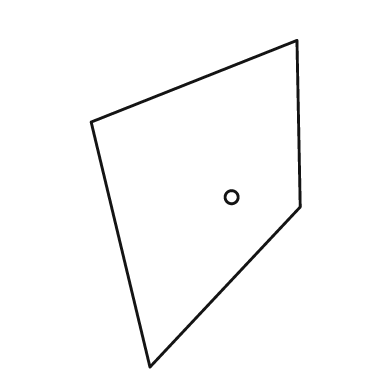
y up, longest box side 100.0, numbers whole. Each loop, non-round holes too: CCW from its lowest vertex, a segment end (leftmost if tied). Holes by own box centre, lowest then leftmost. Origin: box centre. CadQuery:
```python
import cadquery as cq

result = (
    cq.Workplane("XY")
    .moveTo(-14.0, -50.0)
    .lineTo(32.0, -1.0)
    .lineTo(31.0, 50.0)
    .lineTo(-32.0, 25.0)
    .close()
    .moveTo(11.0, 2.0)
    .circle(2.0)
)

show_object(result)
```